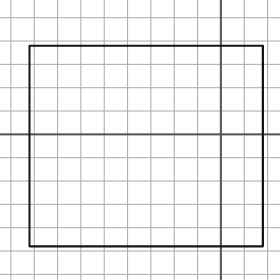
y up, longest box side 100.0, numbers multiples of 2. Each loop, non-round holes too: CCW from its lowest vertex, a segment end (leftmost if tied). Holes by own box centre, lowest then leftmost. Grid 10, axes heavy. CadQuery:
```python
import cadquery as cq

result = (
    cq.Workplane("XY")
    .moveTo(-82.0, -48.0)
    .lineTo(18.0, -48.0)
    .lineTo(18.0, 38.0)
    .lineTo(-82.0, 38.0)
    .close()
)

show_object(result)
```